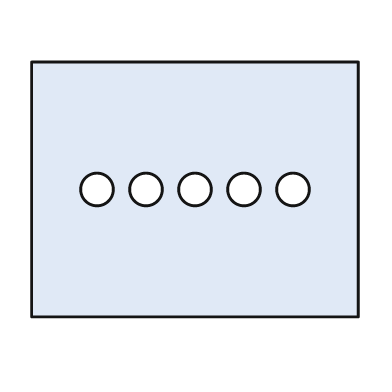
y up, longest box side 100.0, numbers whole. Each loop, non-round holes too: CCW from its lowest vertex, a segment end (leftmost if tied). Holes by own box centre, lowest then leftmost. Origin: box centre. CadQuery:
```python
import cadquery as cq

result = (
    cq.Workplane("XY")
    .moveTo(-50.0, -39.0)
    .lineTo(50.0, -39.0)
    .lineTo(50.0, 39.0)
    .lineTo(-50.0, 39.0)
    .close()
    .moveTo(-30.0, 0.0)
    .circle(5.0)
    .moveTo(-15.0, 0.0)
    .circle(5.0)
    .moveTo(0.0, 0.0)
    .circle(5.0)
    .moveTo(15.0, 0.0)
    .circle(5.0)
    .moveTo(30.0, 0.0)
    .circle(5.0)
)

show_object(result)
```